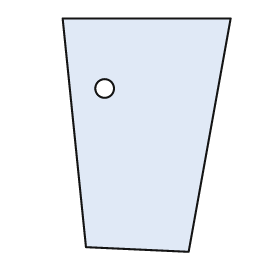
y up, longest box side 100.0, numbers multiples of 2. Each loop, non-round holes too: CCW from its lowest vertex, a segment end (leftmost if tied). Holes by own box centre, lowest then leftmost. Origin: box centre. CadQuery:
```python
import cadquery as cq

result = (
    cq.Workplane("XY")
    .moveTo(18.0, -50.0)
    .lineTo(36.0, 50.0)
    .lineTo(-36.0, 50.0)
    .lineTo(-26.0, -48.0)
    .close()
    .moveTo(-18.0, 20.0)
    .circle(4.0)
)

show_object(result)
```